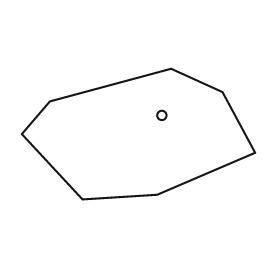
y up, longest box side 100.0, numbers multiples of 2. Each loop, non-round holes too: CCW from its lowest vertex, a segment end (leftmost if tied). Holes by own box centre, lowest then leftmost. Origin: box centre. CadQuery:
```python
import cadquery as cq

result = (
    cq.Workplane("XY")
    .moveTo(-24.0, -28.0)
    .lineTo(8.0, -26.0)
    .lineTo(50.0, -8.0)
    .lineTo(36.0, 18.0)
    .lineTo(14.0, 28.0)
    .lineTo(-38.0, 14.0)
    .lineTo(-50.0, 0.0)
    .close()
    .moveTo(10.0, 8.0)
    .circle(2.0)
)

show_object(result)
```